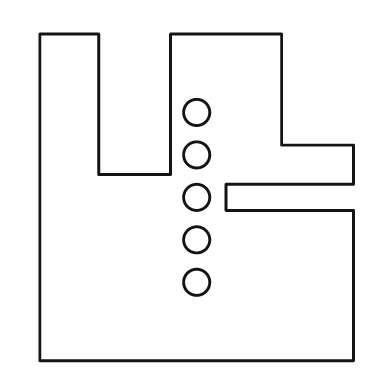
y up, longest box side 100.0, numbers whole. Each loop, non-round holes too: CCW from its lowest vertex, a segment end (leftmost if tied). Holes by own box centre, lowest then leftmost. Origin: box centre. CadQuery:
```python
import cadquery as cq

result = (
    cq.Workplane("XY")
    .moveTo(-48.0, -50.0)
    .lineTo(48.0, -50.0)
    .lineTo(48.0, -4.0)
    .lineTo(9.0, -4.0)
    .lineTo(9.0, 4.0)
    .lineTo(48.0, 4.0)
    .lineTo(48.0, 16.0)
    .lineTo(26.0, 16.0)
    .lineTo(26.0, 50.0)
    .lineTo(-8.0, 50.0)
    .lineTo(-8.0, 7.0)
    .lineTo(-30.0, 7.0)
    .lineTo(-30.0, 50.0)
    .lineTo(-48.0, 50.0)
    .close()
    .moveTo(0.0, -26.0)
    .circle(4.0)
    .moveTo(0.0, -13.0)
    .circle(4.0)
    .moveTo(0.0, 0.0)
    .circle(4.0)
    .moveTo(0.0, 13.0)
    .circle(4.0)
    .moveTo(0.0, 26.0)
    .circle(4.0)
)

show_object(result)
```